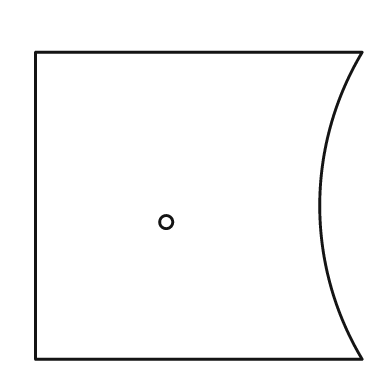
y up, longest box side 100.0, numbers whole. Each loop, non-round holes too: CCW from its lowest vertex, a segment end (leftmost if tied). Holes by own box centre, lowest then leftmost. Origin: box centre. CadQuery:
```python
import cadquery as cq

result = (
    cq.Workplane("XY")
    .moveTo(-50.0, -47.0)
    .lineTo(50.0, -47.0)
    .threePointArc((37.0, 0.0), (50.0, 47.0))
    .lineTo(-50.0, 47.0)
    .close()
    .moveTo(-10.0, -5.0)
    .circle(2.0)
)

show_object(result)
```